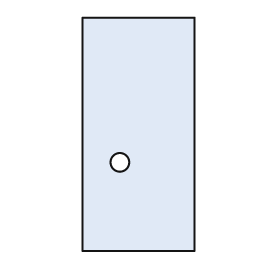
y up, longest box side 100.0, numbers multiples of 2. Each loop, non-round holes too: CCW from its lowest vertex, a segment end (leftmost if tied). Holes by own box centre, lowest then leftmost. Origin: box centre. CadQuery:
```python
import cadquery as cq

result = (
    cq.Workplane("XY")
    .moveTo(-24.0, -50.0)
    .lineTo(24.0, -50.0)
    .lineTo(24.0, 50.0)
    .lineTo(-24.0, 50.0)
    .close()
    .moveTo(-8.0, -12.0)
    .circle(4.0)
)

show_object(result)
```